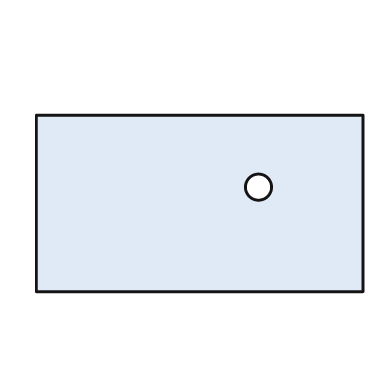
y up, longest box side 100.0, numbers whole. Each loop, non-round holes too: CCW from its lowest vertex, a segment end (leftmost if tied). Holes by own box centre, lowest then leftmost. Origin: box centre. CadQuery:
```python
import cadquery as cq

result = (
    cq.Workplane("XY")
    .moveTo(-50.0, -27.0)
    .lineTo(50.0, -27.0)
    .lineTo(50.0, 27.0)
    .lineTo(-50.0, 27.0)
    .close()
    .moveTo(18.0, 5.0)
    .circle(4.0)
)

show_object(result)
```